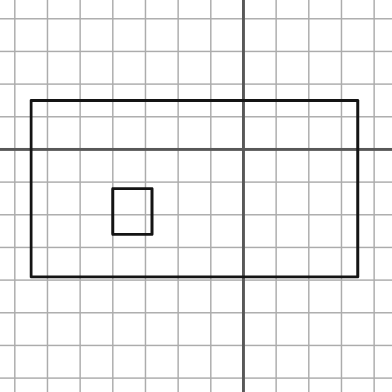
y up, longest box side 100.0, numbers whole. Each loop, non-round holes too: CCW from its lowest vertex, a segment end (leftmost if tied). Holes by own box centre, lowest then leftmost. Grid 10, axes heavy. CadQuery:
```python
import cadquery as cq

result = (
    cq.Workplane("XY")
    .moveTo(-65.0, -39.0)
    .lineTo(35.0, -39.0)
    .lineTo(35.0, 15.0)
    .lineTo(-65.0, 15.0)
    .close()
    .moveTo(-40.0, -26.0)
    .lineTo(-28.0, -26.0)
    .lineTo(-28.0, -12.0)
    .lineTo(-40.0, -12.0)
    .close()
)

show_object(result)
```